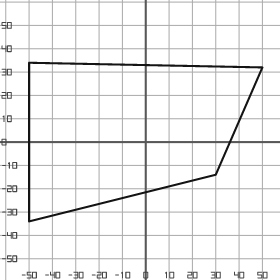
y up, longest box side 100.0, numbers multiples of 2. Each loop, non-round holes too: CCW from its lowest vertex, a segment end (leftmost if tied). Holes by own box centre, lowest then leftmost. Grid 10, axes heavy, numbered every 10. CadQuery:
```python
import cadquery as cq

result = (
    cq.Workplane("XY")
    .moveTo(-50.0, -34.0)
    .lineTo(30.0, -14.0)
    .lineTo(50.0, 32.0)
    .lineTo(-50.0, 34.0)
    .close()
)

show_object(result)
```